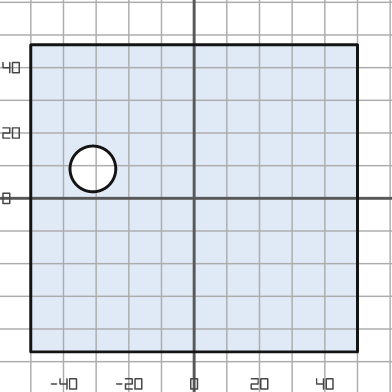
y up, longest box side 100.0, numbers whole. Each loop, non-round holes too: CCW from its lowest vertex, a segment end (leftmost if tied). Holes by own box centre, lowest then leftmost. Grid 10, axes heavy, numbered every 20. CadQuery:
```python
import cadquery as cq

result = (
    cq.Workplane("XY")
    .moveTo(-50.0, -47.0)
    .lineTo(50.0, -47.0)
    .lineTo(50.0, 47.0)
    .lineTo(-50.0, 47.0)
    .close()
    .moveTo(-31.0, 9.0)
    .circle(7.0)
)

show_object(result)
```